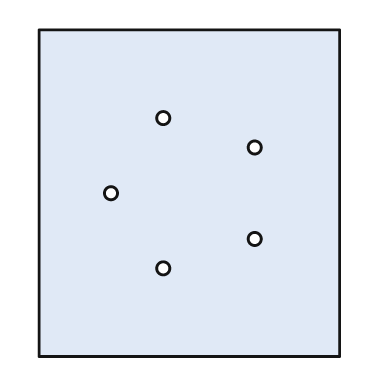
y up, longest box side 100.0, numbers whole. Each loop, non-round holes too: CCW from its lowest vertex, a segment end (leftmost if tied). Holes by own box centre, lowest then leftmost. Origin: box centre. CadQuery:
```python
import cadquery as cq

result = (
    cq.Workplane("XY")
    .moveTo(-46.0, -50.0)
    .lineTo(46.0, -50.0)
    .lineTo(46.0, 50.0)
    .lineTo(-46.0, 50.0)
    .close()
    .moveTo(-8.0, -23.0)
    .circle(2.0)
    .moveTo(20.0, -14.0)
    .circle(2.0)
    .moveTo(-24.0, 0.0)
    .circle(2.0)
    .moveTo(20.0, 14.0)
    .circle(2.0)
    .moveTo(-8.0, 23.0)
    .circle(2.0)
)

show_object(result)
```